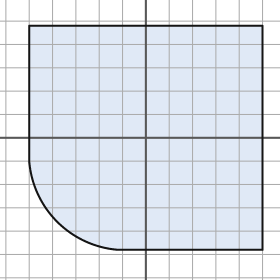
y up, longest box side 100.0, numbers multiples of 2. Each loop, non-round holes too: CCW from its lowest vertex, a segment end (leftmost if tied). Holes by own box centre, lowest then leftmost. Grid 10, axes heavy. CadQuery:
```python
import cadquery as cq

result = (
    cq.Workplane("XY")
    .moveTo(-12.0, -48.0)
    .lineTo(50.0, -48.0)
    .lineTo(50.0, 48.0)
    .lineTo(-50.0, 48.0)
    .lineTo(-50.0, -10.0)
    .threePointArc((-38.0, -36.0), (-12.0, -48.0))
    .close()
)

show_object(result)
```